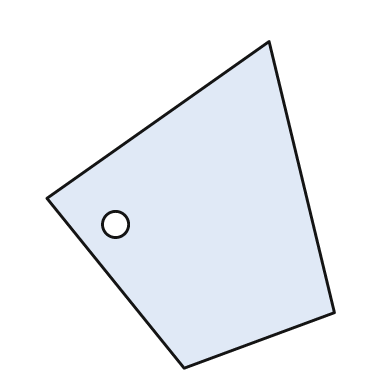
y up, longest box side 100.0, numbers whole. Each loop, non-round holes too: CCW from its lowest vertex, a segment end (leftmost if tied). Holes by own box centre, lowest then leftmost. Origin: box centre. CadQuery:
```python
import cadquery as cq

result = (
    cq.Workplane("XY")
    .moveTo(-2.0, -50.0)
    .lineTo(44.0, -33.0)
    .lineTo(24.0, 50.0)
    .lineTo(-44.0, 2.0)
    .close()
    .moveTo(-23.0, -6.0)
    .circle(4.0)
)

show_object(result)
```